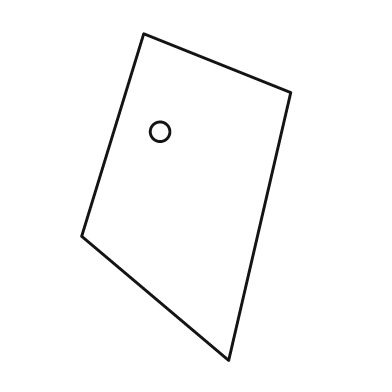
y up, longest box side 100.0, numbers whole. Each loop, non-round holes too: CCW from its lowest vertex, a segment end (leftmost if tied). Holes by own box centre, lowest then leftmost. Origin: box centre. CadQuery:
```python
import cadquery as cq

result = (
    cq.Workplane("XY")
    .moveTo(13.0, -50.0)
    .lineTo(32.0, 32.0)
    .lineTo(-13.0, 50.0)
    .lineTo(-32.0, -12.0)
    .close()
    .moveTo(-8.0, 20.0)
    .circle(3.0)
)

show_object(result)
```